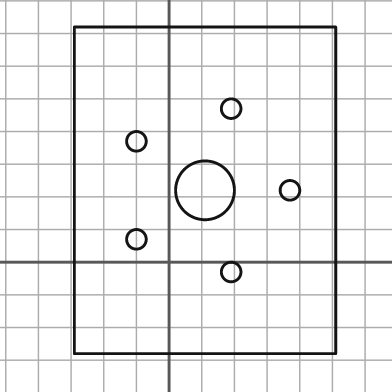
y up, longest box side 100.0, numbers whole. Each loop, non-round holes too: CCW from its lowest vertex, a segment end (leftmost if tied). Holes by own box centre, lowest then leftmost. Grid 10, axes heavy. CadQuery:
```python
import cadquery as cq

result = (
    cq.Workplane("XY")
    .moveTo(-29.0, -28.0)
    .lineTo(51.0, -28.0)
    .lineTo(51.0, 72.0)
    .lineTo(-29.0, 72.0)
    .close()
    .moveTo(19.0, -3.0)
    .circle(3.0)
    .moveTo(-10.0, 7.0)
    .circle(3.0)
    .moveTo(11.0, 22.0)
    .circle(9.0)
    .moveTo(37.0, 22.0)
    .circle(3.0)
    .moveTo(-10.0, 37.0)
    .circle(3.0)
    .moveTo(19.0, 47.0)
    .circle(3.0)
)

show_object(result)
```